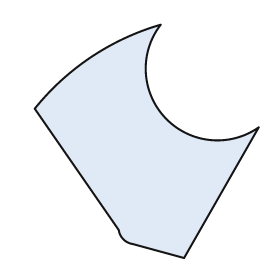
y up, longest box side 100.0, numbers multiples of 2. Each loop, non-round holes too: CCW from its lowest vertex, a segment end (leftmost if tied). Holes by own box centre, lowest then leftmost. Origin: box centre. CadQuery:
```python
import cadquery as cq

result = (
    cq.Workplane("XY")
    .moveTo(16.0, -50.0)
    .lineTo(48.0, 6.0)
    .threePointArc((8.0, 10.0), (6.0, 50.0))
    .threePointArc((-24.0, 36.0), (-48.0, 14.0))
    .lineTo(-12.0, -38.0)
    .threePointArc((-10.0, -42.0), (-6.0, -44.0))
    .close()
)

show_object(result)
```